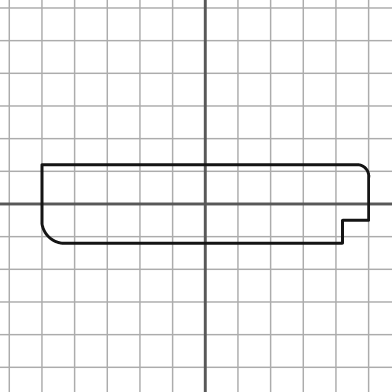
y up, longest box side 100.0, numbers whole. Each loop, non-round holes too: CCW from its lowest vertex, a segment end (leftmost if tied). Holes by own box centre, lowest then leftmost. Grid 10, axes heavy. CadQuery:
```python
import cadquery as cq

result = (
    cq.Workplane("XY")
    .moveTo(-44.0, -12.0)
    .lineTo(42.0, -12.0)
    .lineTo(42.0, -5.0)
    .lineTo(50.0, -5.0)
    .lineTo(50.0, 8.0)
    .threePointArc((49.0, 11.0), (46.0, 12.0))
    .lineTo(-50.0, 12.0)
    .lineTo(-50.0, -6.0)
    .threePointArc((-48.0, -10.0), (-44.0, -12.0))
    .close()
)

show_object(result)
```